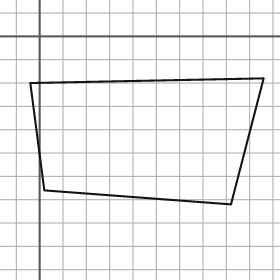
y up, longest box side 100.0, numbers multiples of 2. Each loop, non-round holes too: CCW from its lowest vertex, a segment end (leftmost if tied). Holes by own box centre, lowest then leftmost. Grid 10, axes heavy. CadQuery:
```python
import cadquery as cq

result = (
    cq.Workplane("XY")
    .moveTo(82.0, -72.0)
    .lineTo(96.0, -18.0)
    .lineTo(-4.0, -20.0)
    .lineTo(2.0, -66.0)
    .close()
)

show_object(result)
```